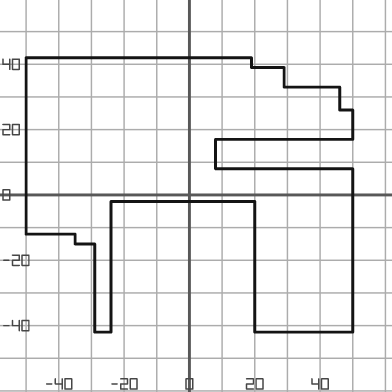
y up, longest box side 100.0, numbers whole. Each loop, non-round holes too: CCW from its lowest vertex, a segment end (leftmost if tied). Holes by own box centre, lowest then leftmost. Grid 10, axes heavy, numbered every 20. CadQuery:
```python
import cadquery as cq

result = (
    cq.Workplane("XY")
    .moveTo(-29.0, -42.0)
    .lineTo(-24.0, -42.0)
    .lineTo(-24.0, -2.0)
    .lineTo(20.0, -2.0)
    .lineTo(20.0, -42.0)
    .lineTo(50.0, -42.0)
    .lineTo(50.0, 8.0)
    .lineTo(8.0, 8.0)
    .lineTo(8.0, 17.0)
    .lineTo(50.0, 17.0)
    .lineTo(50.0, 26.0)
    .lineTo(46.0, 26.0)
    .lineTo(46.0, 33.0)
    .lineTo(29.0, 33.0)
    .lineTo(29.0, 39.0)
    .lineTo(19.0, 39.0)
    .lineTo(19.0, 42.0)
    .lineTo(-50.0, 42.0)
    .lineTo(-50.0, -12.0)
    .lineTo(-35.0, -12.0)
    .lineTo(-35.0, -15.0)
    .lineTo(-29.0, -15.0)
    .close()
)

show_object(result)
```